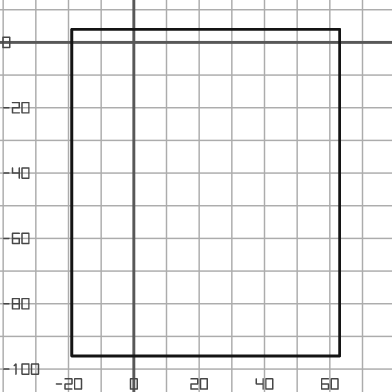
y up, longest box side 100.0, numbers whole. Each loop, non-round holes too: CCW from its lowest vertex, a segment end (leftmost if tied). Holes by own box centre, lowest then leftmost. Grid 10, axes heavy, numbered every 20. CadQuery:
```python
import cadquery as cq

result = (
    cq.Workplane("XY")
    .moveTo(-19.0, -96.0)
    .lineTo(63.0, -96.0)
    .lineTo(63.0, 4.0)
    .lineTo(-19.0, 4.0)
    .close()
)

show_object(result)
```